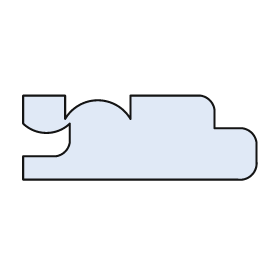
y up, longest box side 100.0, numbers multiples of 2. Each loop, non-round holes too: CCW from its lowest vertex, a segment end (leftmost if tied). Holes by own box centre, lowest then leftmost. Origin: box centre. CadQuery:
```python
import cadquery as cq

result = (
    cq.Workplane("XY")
    .moveTo(-50.0, -18.0)
    .lineTo(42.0, -18.0)
    .threePointArc((48.0, -16.0), (50.0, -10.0))
    .lineTo(50.0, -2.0)
    .threePointArc((48.0, 2.0), (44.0, 4.0))
    .lineTo(32.0, 4.0)
    .lineTo(32.0, 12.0)
    .threePointArc((30.0, 16.0), (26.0, 18.0))
    .lineTo(-4.0, 18.0)
    .lineTo(-4.0, 8.0)
    .threePointArc((-18.0, 16.0), (-32.0, 8.0))
    .lineTo(-32.0, 18.0)
    .lineTo(-50.0, 18.0)
    .lineTo(-50.0, 6.0)
    .threePointArc((-40.0, 2.0), (-30.0, 6.0))
    .lineTo(-30.0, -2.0)
    .threePointArc((-32.0, -6.0), (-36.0, -8.0))
    .lineTo(-50.0, -8.0)
    .close()
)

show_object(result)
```